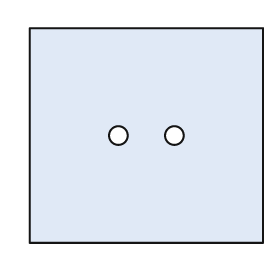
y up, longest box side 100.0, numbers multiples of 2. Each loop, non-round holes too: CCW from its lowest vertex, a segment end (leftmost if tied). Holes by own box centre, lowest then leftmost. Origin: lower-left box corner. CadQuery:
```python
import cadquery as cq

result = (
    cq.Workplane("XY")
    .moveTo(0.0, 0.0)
    .lineTo(100.0, 0.0)
    .lineTo(100.0, 92.0)
    .lineTo(0.0, 92.0)
    .close()
    .moveTo(38.0, 46.0)
    .circle(4.0)
    .moveTo(62.0, 46.0)
    .circle(4.0)
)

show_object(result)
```